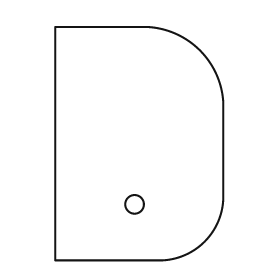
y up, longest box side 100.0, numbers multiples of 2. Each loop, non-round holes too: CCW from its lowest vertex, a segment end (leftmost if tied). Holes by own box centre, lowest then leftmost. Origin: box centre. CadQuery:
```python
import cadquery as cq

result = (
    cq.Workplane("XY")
    .moveTo(-36.0, -50.0)
    .lineTo(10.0, -50.0)
    .threePointArc((28.0, -42.0), (36.0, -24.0))
    .lineTo(36.0, 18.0)
    .threePointArc((26.0, 40.0), (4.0, 50.0))
    .lineTo(-36.0, 50.0)
    .close()
    .moveTo(-2.0, -26.0)
    .circle(4.0)
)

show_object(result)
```